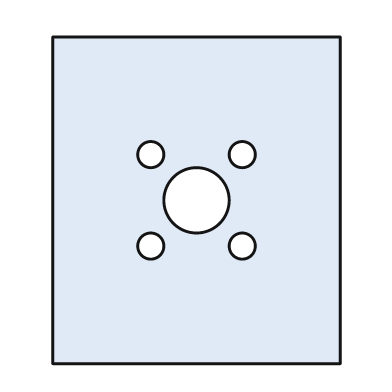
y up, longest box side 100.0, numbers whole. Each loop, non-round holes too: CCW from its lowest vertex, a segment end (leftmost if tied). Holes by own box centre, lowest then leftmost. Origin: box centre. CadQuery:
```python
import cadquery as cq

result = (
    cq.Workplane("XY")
    .moveTo(-44.0, -50.0)
    .lineTo(44.0, -50.0)
    .lineTo(44.0, 50.0)
    .lineTo(-44.0, 50.0)
    .close()
    .moveTo(-14.0, -14.0)
    .circle(4.0)
    .moveTo(14.0, -14.0)
    .circle(4.0)
    .moveTo(0.0, 0.0)
    .circle(10.0)
    .moveTo(-14.0, 14.0)
    .circle(4.0)
    .moveTo(14.0, 14.0)
    .circle(4.0)
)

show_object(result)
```